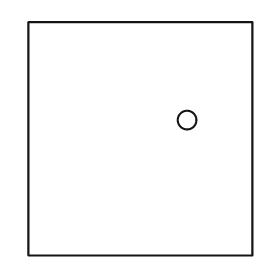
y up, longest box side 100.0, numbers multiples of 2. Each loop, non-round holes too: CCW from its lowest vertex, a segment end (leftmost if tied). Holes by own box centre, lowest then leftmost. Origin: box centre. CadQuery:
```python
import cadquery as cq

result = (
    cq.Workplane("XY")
    .moveTo(-48.0, -50.0)
    .lineTo(48.0, -50.0)
    .lineTo(48.0, 50.0)
    .lineTo(-48.0, 50.0)
    .close()
    .moveTo(20.0, 8.0)
    .circle(4.0)
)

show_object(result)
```